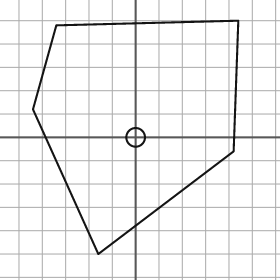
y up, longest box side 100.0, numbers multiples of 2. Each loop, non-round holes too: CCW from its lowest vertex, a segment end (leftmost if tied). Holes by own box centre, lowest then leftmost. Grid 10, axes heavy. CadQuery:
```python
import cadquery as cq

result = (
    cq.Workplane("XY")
    .moveTo(-16.0, -50.0)
    .lineTo(42.0, -6.0)
    .lineTo(44.0, 50.0)
    .lineTo(-34.0, 48.0)
    .lineTo(-44.0, 12.0)
    .close()
    .moveTo(0.0, 0.0)
    .circle(4.0)
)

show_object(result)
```